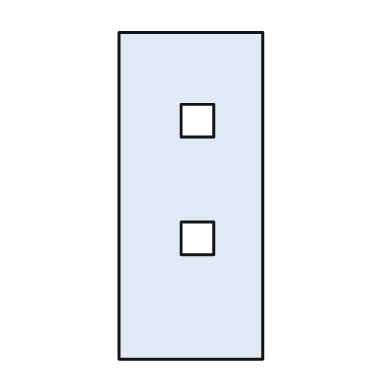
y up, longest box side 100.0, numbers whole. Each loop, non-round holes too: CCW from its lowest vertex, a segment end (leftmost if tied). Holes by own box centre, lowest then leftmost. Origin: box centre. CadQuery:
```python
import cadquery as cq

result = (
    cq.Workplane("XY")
    .moveTo(-22.0, -50.0)
    .lineTo(22.0, -50.0)
    .lineTo(22.0, 50.0)
    .lineTo(-22.0, 50.0)
    .close()
    .moveTo(-3.0, -18.0)
    .lineTo(7.0, -18.0)
    .lineTo(7.0, -8.0)
    .lineTo(-3.0, -8.0)
    .close()
    .moveTo(-3.0, 18.0)
    .lineTo(7.0, 18.0)
    .lineTo(7.0, 28.0)
    .lineTo(-3.0, 28.0)
    .close()
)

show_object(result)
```